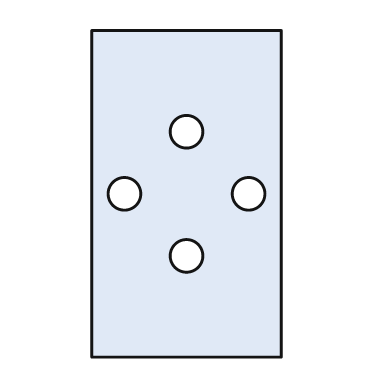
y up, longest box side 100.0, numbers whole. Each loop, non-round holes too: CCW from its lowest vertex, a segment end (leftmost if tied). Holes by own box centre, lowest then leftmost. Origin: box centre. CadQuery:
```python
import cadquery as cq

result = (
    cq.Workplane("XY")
    .moveTo(-29.0, -50.0)
    .lineTo(29.0, -50.0)
    .lineTo(29.0, 50.0)
    .lineTo(-29.0, 50.0)
    .close()
    .moveTo(0.0, -19.0)
    .circle(5.0)
    .moveTo(-19.0, 0.0)
    .circle(5.0)
    .moveTo(19.0, 0.0)
    .circle(5.0)
    .moveTo(0.0, 19.0)
    .circle(5.0)
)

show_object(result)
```